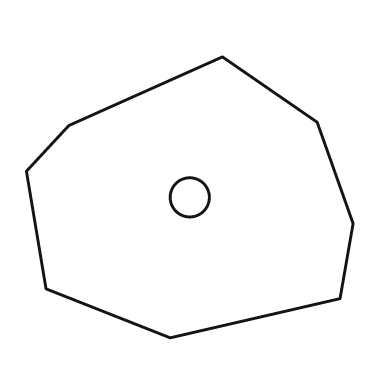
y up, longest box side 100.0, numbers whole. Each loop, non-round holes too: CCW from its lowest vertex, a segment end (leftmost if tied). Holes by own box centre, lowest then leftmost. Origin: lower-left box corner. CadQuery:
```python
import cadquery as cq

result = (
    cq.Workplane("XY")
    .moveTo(44.0, 0.0)
    .lineTo(96.0, 12.0)
    .lineTo(100.0, 35.0)
    .lineTo(89.0, 66.0)
    .lineTo(60.0, 86.0)
    .lineTo(13.0, 65.0)
    .lineTo(0.0, 51.0)
    .lineTo(6.0, 15.0)
    .close()
    .moveTo(50.0, 43.0)
    .circle(6.0)
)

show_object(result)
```